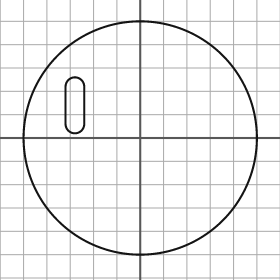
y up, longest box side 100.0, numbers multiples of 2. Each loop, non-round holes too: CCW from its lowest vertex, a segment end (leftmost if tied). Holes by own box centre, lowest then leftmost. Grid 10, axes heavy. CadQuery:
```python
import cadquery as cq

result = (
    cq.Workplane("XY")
    .moveTo(0.0, 0.0)
    .circle(50.0)
    .moveTo(-32.0, 6.0)
    .threePointArc((-28.0, 2.0), (-24.0, 6.0))
    .lineTo(-24.0, 22.0)
    .threePointArc((-28.0, 26.0), (-32.0, 22.0))
    .close()
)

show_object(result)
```